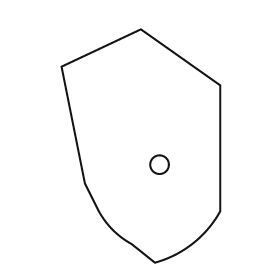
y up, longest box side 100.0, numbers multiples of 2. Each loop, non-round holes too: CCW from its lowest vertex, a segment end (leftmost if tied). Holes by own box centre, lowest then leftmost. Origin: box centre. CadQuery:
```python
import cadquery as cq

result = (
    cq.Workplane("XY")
    .moveTo(6.0, -50.0)
    .threePointArc((22.0, -42.0), (34.0, -28.0))
    .lineTo(34.0, 26.0)
    .lineTo(0.0, 50.0)
    .lineTo(-34.0, 34.0)
    .lineTo(-24.0, -16.0)
    .lineTo(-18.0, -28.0)
    .threePointArc((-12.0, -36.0), (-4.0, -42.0))
    .close()
    .moveTo(8.0, -8.0)
    .circle(4.0)
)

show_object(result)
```